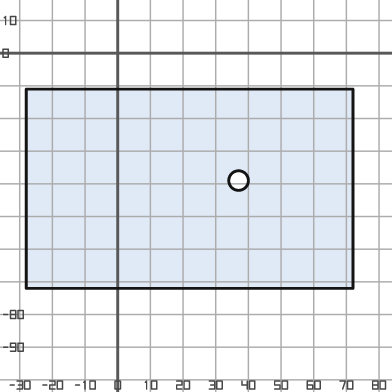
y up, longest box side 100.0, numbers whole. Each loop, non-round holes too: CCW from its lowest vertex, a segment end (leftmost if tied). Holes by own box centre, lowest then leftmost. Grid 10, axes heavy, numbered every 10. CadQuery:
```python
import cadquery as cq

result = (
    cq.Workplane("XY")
    .moveTo(-28.0, -72.0)
    .lineTo(72.0, -72.0)
    .lineTo(72.0, -11.0)
    .lineTo(-28.0, -11.0)
    .close()
    .moveTo(37.0, -39.0)
    .circle(3.0)
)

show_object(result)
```